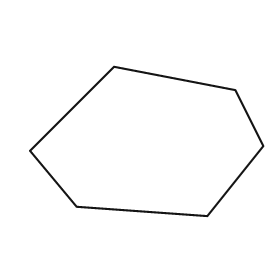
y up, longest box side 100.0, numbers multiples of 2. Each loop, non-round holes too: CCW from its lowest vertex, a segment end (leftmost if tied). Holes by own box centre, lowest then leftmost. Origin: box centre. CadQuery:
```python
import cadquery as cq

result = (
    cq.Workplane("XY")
    .moveTo(26.0, -32.0)
    .lineTo(50.0, -2.0)
    .lineTo(38.0, 22.0)
    .lineTo(-14.0, 32.0)
    .lineTo(-50.0, -4.0)
    .lineTo(-30.0, -28.0)
    .close()
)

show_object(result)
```